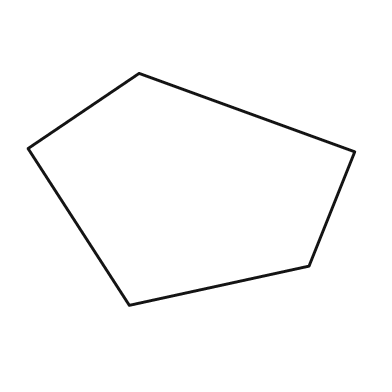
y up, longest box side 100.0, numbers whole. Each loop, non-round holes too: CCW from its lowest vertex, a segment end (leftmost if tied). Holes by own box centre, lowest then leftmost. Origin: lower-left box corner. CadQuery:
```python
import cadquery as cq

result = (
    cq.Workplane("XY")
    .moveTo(31.0, 0.0)
    .lineTo(86.0, 12.0)
    .lineTo(100.0, 47.0)
    .lineTo(34.0, 71.0)
    .lineTo(0.0, 48.0)
    .close()
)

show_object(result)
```